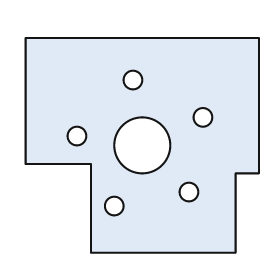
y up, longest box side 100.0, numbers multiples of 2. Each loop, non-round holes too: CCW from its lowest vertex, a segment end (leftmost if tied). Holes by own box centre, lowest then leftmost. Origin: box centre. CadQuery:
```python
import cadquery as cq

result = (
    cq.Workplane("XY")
    .moveTo(-22.0, -46.0)
    .lineTo(40.0, -46.0)
    .lineTo(40.0, -12.0)
    .lineTo(50.0, -12.0)
    .lineTo(50.0, 46.0)
    .lineTo(-50.0, 46.0)
    .lineTo(-50.0, -8.0)
    .lineTo(-22.0, -8.0)
    .close()
    .moveTo(-12.0, -26.0)
    .circle(4.0)
    .moveTo(20.0, -20.0)
    .circle(4.0)
    .moveTo(0.0, 0.0)
    .circle(12.0)
    .moveTo(-28.0, 4.0)
    .circle(4.0)
    .moveTo(26.0, 12.0)
    .circle(4.0)
    .moveTo(-4.0, 28.0)
    .circle(4.0)
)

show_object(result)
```